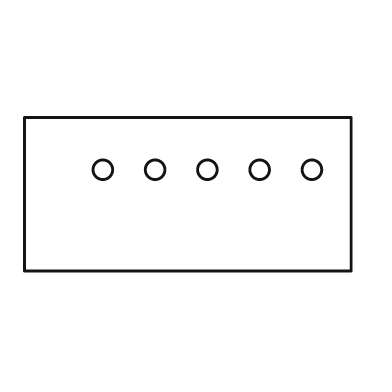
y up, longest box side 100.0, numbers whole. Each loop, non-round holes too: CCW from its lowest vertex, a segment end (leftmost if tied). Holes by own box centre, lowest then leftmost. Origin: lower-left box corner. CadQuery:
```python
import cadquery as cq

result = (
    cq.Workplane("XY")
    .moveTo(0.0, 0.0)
    .lineTo(100.0, 0.0)
    .lineTo(100.0, 47.0)
    .lineTo(0.0, 47.0)
    .close()
    .moveTo(24.0, 31.0)
    .circle(3.0)
    .moveTo(40.0, 31.0)
    .circle(3.0)
    .moveTo(56.0, 31.0)
    .circle(3.0)
    .moveTo(72.0, 31.0)
    .circle(3.0)
    .moveTo(88.0, 31.0)
    .circle(3.0)
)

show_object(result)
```